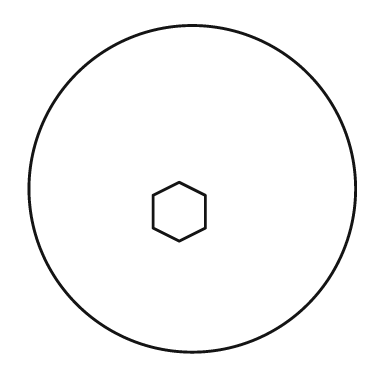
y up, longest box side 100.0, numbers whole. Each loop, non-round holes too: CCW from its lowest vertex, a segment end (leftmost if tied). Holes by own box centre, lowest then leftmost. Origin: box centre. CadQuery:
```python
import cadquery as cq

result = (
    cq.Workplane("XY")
    .moveTo(0.0, 0.0)
    .circle(50.0)
    .moveTo(-4.0, -16.0)
    .lineTo(4.0, -12.0)
    .lineTo(4.0, -2.0)
    .lineTo(-4.0, 2.0)
    .lineTo(-12.0, -2.0)
    .lineTo(-12.0, -12.0)
    .close()
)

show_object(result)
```